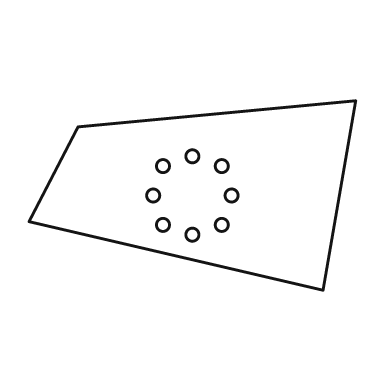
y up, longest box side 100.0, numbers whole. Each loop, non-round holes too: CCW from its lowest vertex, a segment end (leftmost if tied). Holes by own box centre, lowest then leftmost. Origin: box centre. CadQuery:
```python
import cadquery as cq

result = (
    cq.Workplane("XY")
    .moveTo(40.0, -29.0)
    .lineTo(50.0, 29.0)
    .lineTo(-35.0, 21.0)
    .lineTo(-50.0, -8.0)
    .close()
    .moveTo(0.0, -12.0)
    .circle(2.0)
    .moveTo(-9.0, -9.0)
    .circle(2.0)
    .moveTo(9.0, -9.0)
    .circle(2.0)
    .moveTo(-12.0, 0.0)
    .circle(2.0)
    .moveTo(12.0, 0.0)
    .circle(2.0)
    .moveTo(-9.0, 9.0)
    .circle(2.0)
    .moveTo(9.0, 9.0)
    .circle(2.0)
    .moveTo(0.0, 12.0)
    .circle(2.0)
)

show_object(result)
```